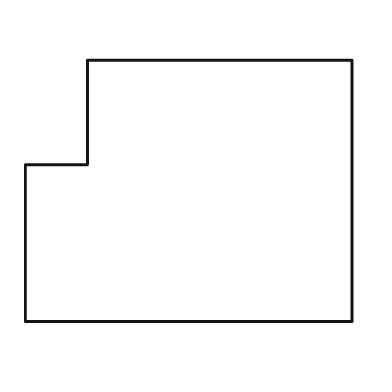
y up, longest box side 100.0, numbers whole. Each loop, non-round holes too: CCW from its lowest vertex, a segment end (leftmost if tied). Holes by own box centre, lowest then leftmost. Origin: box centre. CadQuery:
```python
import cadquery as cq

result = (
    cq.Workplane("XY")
    .moveTo(-50.0, -40.0)
    .lineTo(50.0, -40.0)
    .lineTo(50.0, 40.0)
    .lineTo(-31.0, 40.0)
    .lineTo(-31.0, 8.0)
    .lineTo(-50.0, 8.0)
    .close()
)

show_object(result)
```